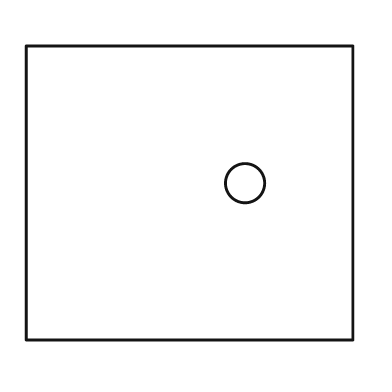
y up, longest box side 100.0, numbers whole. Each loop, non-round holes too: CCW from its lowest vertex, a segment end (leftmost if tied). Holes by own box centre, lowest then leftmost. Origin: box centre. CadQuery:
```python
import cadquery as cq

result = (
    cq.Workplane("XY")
    .moveTo(-50.0, -45.0)
    .lineTo(50.0, -45.0)
    .lineTo(50.0, 45.0)
    .lineTo(-50.0, 45.0)
    .close()
    .moveTo(17.0, 3.0)
    .circle(6.0)
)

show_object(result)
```